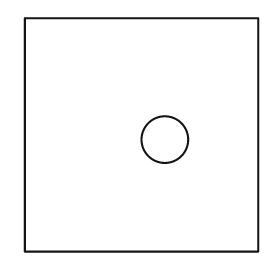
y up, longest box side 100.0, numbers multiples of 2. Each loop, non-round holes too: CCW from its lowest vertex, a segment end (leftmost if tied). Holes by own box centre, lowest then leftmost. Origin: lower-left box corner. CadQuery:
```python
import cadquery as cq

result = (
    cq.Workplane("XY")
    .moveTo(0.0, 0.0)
    .lineTo(100.0, 0.0)
    .lineTo(100.0, 100.0)
    .lineTo(0.0, 100.0)
    .close()
    .moveTo(60.0, 48.0)
    .circle(10.0)
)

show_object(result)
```